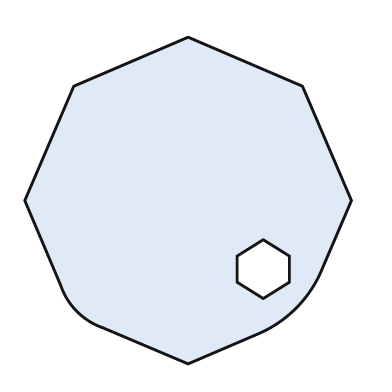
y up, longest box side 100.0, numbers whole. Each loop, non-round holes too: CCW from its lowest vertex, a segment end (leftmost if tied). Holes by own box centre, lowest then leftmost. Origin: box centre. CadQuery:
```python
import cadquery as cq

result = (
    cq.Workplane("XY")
    .moveTo(0.0, -50.0)
    .lineTo(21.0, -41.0)
    .threePointArc((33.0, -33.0), (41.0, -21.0))
    .lineTo(50.0, 0.0)
    .lineTo(35.0, 35.0)
    .lineTo(0.0, 50.0)
    .lineTo(-35.0, 35.0)
    .lineTo(-50.0, 0.0)
    .lineTo(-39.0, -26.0)
    .threePointArc((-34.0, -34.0), (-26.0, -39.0))
    .close()
    .moveTo(23.0, -30.0)
    .lineTo(31.0, -25.0)
    .lineTo(31.0, -17.0)
    .lineTo(23.0, -12.0)
    .lineTo(15.0, -17.0)
    .lineTo(15.0, -25.0)
    .close()
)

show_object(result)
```